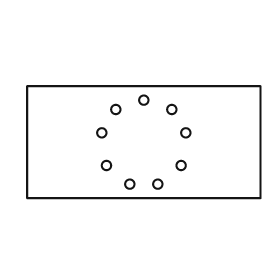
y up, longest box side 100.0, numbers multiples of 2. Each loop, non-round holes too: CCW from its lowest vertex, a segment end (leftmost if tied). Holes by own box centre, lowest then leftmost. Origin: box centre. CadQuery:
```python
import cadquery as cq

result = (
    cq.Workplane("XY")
    .moveTo(-50.0, -24.0)
    .lineTo(50.0, -24.0)
    .lineTo(50.0, 24.0)
    .lineTo(-50.0, 24.0)
    .close()
    .moveTo(-6.0, -18.0)
    .circle(2.0)
    .moveTo(6.0, -18.0)
    .circle(2.0)
    .moveTo(-16.0, -10.0)
    .circle(2.0)
    .moveTo(16.0, -10.0)
    .circle(2.0)
    .moveTo(-18.0, 4.0)
    .circle(2.0)
    .moveTo(18.0, 4.0)
    .circle(2.0)
    .moveTo(-12.0, 14.0)
    .circle(2.0)
    .moveTo(12.0, 14.0)
    .circle(2.0)
    .moveTo(0.0, 18.0)
    .circle(2.0)
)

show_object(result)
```